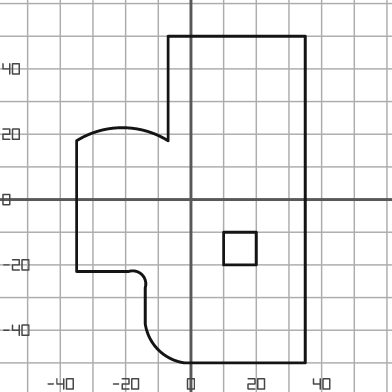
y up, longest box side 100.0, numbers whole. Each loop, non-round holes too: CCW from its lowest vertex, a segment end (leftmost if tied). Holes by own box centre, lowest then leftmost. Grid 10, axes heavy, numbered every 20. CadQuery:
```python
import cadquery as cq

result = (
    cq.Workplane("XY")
    .moveTo(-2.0, -50.0)
    .lineTo(35.0, -50.0)
    .lineTo(35.0, 50.0)
    .lineTo(-7.0, 50.0)
    .lineTo(-7.0, 18.0)
    .threePointArc((-21.0, 22.0), (-35.0, 18.0))
    .lineTo(-35.0, -22.0)
    .lineTo(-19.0, -22.0)
    .threePointArc((-15.0, -23.0), (-14.0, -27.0))
    .lineTo(-14.0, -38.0)
    .threePointArc((-10.0, -46.0), (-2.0, -50.0))
    .close()
    .moveTo(10.0, -20.0)
    .lineTo(20.0, -20.0)
    .lineTo(20.0, -10.0)
    .lineTo(10.0, -10.0)
    .close()
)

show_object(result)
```